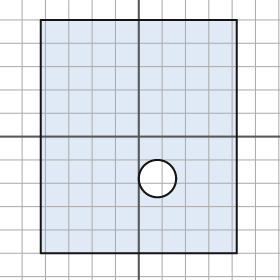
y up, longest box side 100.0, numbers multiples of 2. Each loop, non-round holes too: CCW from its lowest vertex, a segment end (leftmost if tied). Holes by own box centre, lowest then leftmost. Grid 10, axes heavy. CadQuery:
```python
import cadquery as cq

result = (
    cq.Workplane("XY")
    .moveTo(-42.0, -50.0)
    .lineTo(42.0, -50.0)
    .lineTo(42.0, 50.0)
    .lineTo(-42.0, 50.0)
    .close()
    .moveTo(8.0, -18.0)
    .circle(8.0)
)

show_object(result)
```